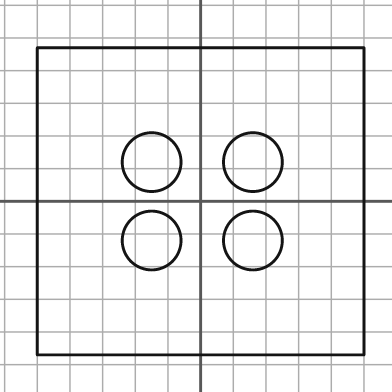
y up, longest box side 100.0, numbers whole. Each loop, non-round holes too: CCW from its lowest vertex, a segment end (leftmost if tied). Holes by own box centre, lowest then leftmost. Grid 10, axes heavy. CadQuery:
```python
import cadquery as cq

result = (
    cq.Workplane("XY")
    .moveTo(-50.0, -47.0)
    .lineTo(50.0, -47.0)
    .lineTo(50.0, 47.0)
    .lineTo(-50.0, 47.0)
    .close()
    .moveTo(-15.0, -12.0)
    .circle(9.0)
    .moveTo(16.0, -12.0)
    .circle(9.0)
    .moveTo(-15.0, 12.0)
    .circle(9.0)
    .moveTo(16.0, 12.0)
    .circle(9.0)
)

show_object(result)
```